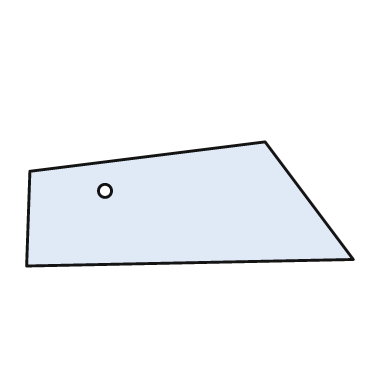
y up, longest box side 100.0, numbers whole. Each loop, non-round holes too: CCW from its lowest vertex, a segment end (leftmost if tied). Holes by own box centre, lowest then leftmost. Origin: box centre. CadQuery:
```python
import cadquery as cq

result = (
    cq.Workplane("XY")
    .moveTo(-50.0, -19.0)
    .lineTo(50.0, -17.0)
    .lineTo(23.0, 19.0)
    .lineTo(-49.0, 10.0)
    .close()
    .moveTo(-26.0, 4.0)
    .circle(2.0)
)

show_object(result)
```